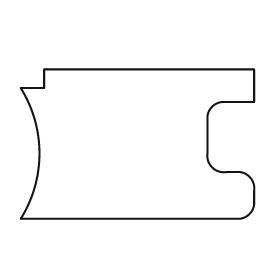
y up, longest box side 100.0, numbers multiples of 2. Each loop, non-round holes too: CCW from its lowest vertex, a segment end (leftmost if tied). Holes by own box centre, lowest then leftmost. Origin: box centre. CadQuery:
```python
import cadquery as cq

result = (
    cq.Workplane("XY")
    .moveTo(-50.0, -32.0)
    .lineTo(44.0, -32.0)
    .threePointArc((48.0, -30.0), (50.0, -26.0))
    .lineTo(50.0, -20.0)
    .threePointArc((48.0, -14.0), (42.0, -12.0))
    .lineTo(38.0, -12.0)
    .threePointArc((32.0, -10.0), (30.0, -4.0))
    .lineTo(30.0, 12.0)
    .threePointArc((32.0, 16.0), (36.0, 18.0))
    .lineTo(50.0, 18.0)
    .lineTo(50.0, 32.0)
    .lineTo(-40.0, 32.0)
    .lineTo(-40.0, 24.0)
    .lineTo(-50.0, 24.0)
    .threePointArc((-42.0, -4.0), (-50.0, -32.0))
    .close()
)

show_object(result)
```